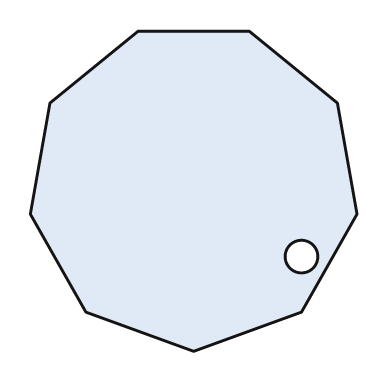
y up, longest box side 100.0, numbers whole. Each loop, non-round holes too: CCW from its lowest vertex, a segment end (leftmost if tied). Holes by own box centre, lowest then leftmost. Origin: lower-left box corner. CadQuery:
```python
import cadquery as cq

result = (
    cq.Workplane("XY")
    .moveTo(50.0, 0.0)
    .lineTo(83.0, 12.0)
    .lineTo(100.0, 42.0)
    .lineTo(94.0, 76.0)
    .lineTo(67.0, 98.0)
    .lineTo(33.0, 98.0)
    .lineTo(6.0, 76.0)
    .lineTo(0.0, 42.0)
    .lineTo(17.0, 12.0)
    .close()
    .moveTo(83.0, 29.0)
    .circle(5.0)
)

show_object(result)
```